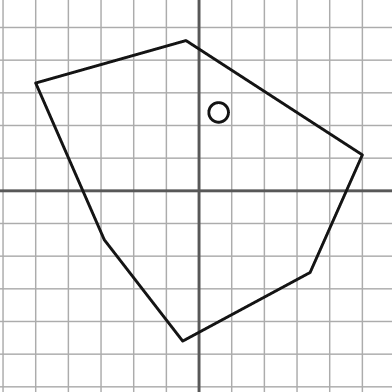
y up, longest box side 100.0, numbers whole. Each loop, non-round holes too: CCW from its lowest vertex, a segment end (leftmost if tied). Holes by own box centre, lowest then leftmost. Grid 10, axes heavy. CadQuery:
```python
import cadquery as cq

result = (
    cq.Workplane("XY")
    .moveTo(-5.0, -46.0)
    .lineTo(34.0, -25.0)
    .lineTo(50.0, 11.0)
    .lineTo(-4.0, 46.0)
    .lineTo(-50.0, 33.0)
    .lineTo(-29.0, -15.0)
    .close()
    .moveTo(6.0, 24.0)
    .circle(3.0)
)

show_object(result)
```